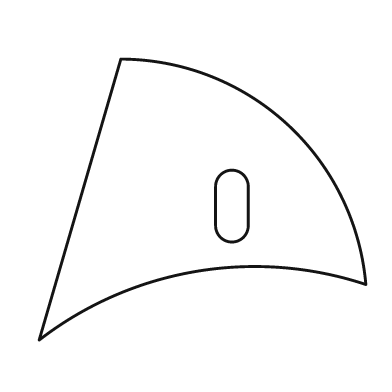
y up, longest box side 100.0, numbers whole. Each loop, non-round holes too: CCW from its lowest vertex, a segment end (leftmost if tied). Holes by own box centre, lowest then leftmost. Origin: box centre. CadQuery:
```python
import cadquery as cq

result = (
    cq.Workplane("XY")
    .moveTo(-50.0, -43.0)
    .threePointArc((-2.0, -22.0), (50.0, -26.0))
    .threePointArc((26.0, 23.0), (-25.0, 43.0))
    .close()
    .moveTo(4.0, -8.0)
    .threePointArc((9.0, -13.0), (14.0, -8.0))
    .lineTo(14.0, 4.0)
    .threePointArc((9.0, 9.0), (4.0, 4.0))
    .close()
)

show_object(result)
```